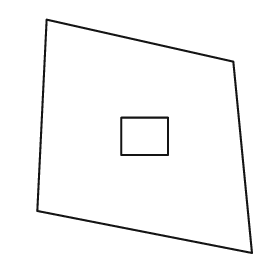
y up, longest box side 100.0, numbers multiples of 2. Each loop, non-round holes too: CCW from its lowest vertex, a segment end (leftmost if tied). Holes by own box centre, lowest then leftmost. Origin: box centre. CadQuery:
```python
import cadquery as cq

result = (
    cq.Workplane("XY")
    .moveTo(46.0, -50.0)
    .lineTo(38.0, 32.0)
    .lineTo(-42.0, 50.0)
    .lineTo(-46.0, -32.0)
    .close()
    .moveTo(-10.0, -8.0)
    .lineTo(10.0, -8.0)
    .lineTo(10.0, 8.0)
    .lineTo(-10.0, 8.0)
    .close()
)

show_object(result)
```